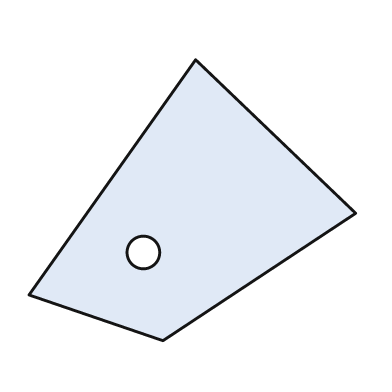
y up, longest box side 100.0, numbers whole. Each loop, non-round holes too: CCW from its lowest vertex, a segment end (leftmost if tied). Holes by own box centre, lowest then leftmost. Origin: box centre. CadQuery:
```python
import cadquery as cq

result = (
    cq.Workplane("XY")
    .moveTo(-9.0, -43.0)
    .lineTo(50.0, -4.0)
    .lineTo(1.0, 43.0)
    .lineTo(-50.0, -29.0)
    .close()
    .moveTo(-15.0, -16.0)
    .circle(5.0)
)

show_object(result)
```